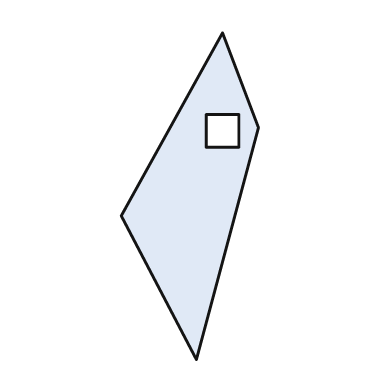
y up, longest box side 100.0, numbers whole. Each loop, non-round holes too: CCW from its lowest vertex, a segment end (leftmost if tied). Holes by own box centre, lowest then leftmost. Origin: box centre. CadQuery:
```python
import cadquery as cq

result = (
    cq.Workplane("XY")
    .moveTo(2.0, -50.0)
    .lineTo(21.0, 21.0)
    .lineTo(10.0, 50.0)
    .lineTo(-21.0, -6.0)
    .close()
    .moveTo(5.0, 15.0)
    .lineTo(15.0, 15.0)
    .lineTo(15.0, 25.0)
    .lineTo(5.0, 25.0)
    .close()
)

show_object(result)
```